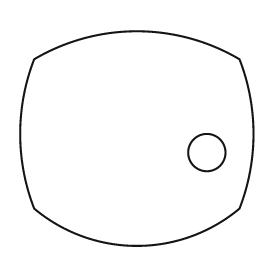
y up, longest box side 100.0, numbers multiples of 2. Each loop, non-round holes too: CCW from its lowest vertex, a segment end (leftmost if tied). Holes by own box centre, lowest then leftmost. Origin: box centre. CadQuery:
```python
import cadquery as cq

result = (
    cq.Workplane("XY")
    .moveTo(-44.0, -30.0)
    .threePointArc((0.0, -46.0), (44.0, -30.0))
    .threePointArc((50.0, 2.0), (44.0, 34.0))
    .threePointArc((0.0, 46.0), (-44.0, 34.0))
    .threePointArc((-50.0, 2.0), (-44.0, -30.0))
    .close()
    .moveTo(30.0, -6.0)
    .circle(8.0)
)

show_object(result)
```